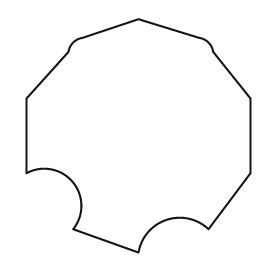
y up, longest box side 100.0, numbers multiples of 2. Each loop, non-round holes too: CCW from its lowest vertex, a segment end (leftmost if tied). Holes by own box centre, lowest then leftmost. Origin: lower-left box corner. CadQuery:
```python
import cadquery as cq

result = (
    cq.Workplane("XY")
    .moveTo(48.0, 0.0)
    .threePointArc((60.0, 14.0), (78.0, 10.0))
    .lineTo(96.0, 34.0)
    .lineTo(96.0, 66.0)
    .lineTo(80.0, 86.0)
    .threePointArc((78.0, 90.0), (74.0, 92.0))
    .lineTo(48.0, 100.0)
    .lineTo(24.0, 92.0)
    .threePointArc((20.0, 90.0), (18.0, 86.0))
    .lineTo(0.0, 66.0)
    .lineTo(0.0, 34.0)
    .threePointArc((20.0, 30.0), (20.0, 10.0))
    .close()
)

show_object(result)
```